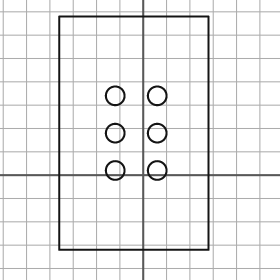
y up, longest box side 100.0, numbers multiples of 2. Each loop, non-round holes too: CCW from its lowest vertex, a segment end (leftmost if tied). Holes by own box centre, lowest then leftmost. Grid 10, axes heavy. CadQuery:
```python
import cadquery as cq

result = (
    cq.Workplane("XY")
    .moveTo(-36.0, -32.0)
    .lineTo(28.0, -32.0)
    .lineTo(28.0, 68.0)
    .lineTo(-36.0, 68.0)
    .close()
    .moveTo(-12.0, 2.0)
    .circle(4.0)
    .moveTo(6.0, 2.0)
    .circle(4.0)
    .moveTo(-12.0, 18.0)
    .circle(4.0)
    .moveTo(6.0, 18.0)
    .circle(4.0)
    .moveTo(-12.0, 34.0)
    .circle(4.0)
    .moveTo(6.0, 34.0)
    .circle(4.0)
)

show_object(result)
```